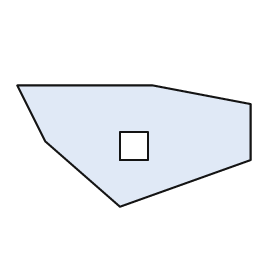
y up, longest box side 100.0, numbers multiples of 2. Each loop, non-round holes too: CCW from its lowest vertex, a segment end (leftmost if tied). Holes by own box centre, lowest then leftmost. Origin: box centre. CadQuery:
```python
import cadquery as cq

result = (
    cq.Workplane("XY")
    .moveTo(-6.0, -26.0)
    .lineTo(50.0, -6.0)
    .lineTo(50.0, 18.0)
    .lineTo(8.0, 26.0)
    .lineTo(-50.0, 26.0)
    .lineTo(-38.0, 2.0)
    .close()
    .moveTo(-6.0, -6.0)
    .lineTo(6.0, -6.0)
    .lineTo(6.0, 6.0)
    .lineTo(-6.0, 6.0)
    .close()
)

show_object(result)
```